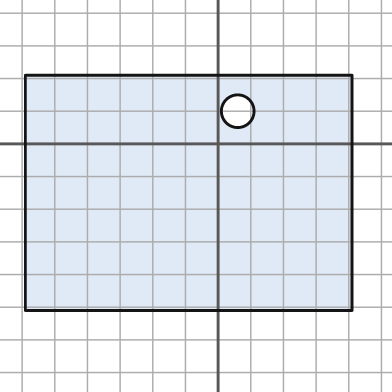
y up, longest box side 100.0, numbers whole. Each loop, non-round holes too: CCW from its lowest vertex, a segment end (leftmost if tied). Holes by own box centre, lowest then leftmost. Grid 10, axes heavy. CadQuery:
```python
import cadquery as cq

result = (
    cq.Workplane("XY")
    .moveTo(-59.0, -51.0)
    .lineTo(41.0, -51.0)
    .lineTo(41.0, 21.0)
    .lineTo(-59.0, 21.0)
    .close()
    .moveTo(6.0, 10.0)
    .circle(5.0)
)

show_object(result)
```